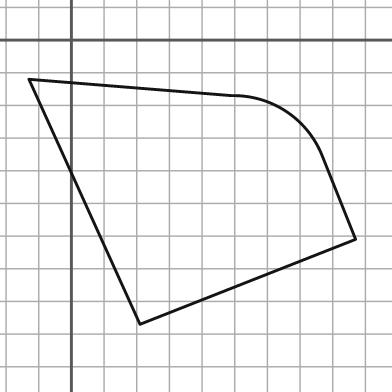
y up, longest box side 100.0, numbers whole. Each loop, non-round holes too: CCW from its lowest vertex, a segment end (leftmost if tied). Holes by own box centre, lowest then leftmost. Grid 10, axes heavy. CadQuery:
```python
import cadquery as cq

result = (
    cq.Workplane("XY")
    .moveTo(21.0, -87.0)
    .lineTo(87.0, -61.0)
    .lineTo(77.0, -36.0)
    .threePointArc((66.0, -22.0), (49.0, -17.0))
    .lineTo(-13.0, -12.0)
    .close()
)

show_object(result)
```